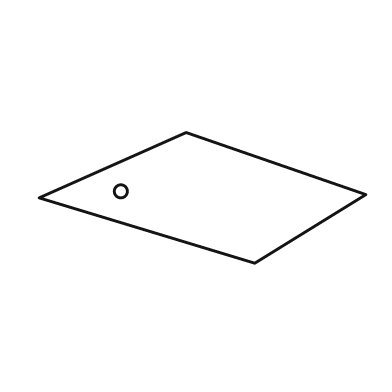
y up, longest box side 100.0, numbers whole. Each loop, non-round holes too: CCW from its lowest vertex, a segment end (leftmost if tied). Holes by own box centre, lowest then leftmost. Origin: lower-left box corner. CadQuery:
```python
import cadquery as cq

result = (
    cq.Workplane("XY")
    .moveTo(66.0, 0.0)
    .lineTo(100.0, 21.0)
    .lineTo(45.0, 40.0)
    .lineTo(0.0, 20.0)
    .close()
    .moveTo(25.0, 22.0)
    .circle(2.0)
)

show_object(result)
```